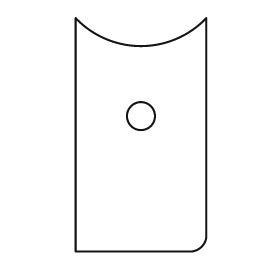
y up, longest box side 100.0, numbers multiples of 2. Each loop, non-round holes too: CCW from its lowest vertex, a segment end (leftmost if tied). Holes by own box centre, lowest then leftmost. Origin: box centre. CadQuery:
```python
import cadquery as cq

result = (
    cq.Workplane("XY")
    .moveTo(-28.0, -50.0)
    .lineTo(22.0, -50.0)
    .threePointArc((26.0, -48.0), (28.0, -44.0))
    .lineTo(28.0, 50.0)
    .threePointArc((0.0, 38.0), (-28.0, 50.0))
    .close()
    .moveTo(0.0, 8.0)
    .circle(6.0)
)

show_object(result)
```